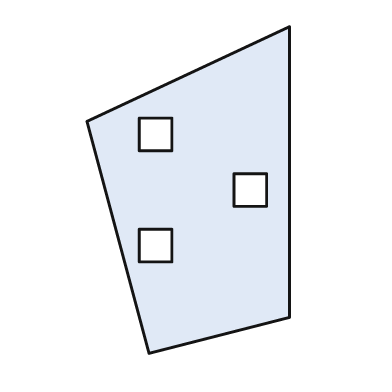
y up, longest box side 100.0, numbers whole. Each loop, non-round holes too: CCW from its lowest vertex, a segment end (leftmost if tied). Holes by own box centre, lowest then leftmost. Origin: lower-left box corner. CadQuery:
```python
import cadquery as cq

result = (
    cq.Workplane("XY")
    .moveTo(19.0, 0.0)
    .lineTo(62.0, 11.0)
    .lineTo(62.0, 100.0)
    .lineTo(0.0, 71.0)
    .close()
    .moveTo(16.0, 28.0)
    .lineTo(26.0, 28.0)
    .lineTo(26.0, 38.0)
    .lineTo(16.0, 38.0)
    .close()
    .moveTo(45.0, 45.0)
    .lineTo(55.0, 45.0)
    .lineTo(55.0, 55.0)
    .lineTo(45.0, 55.0)
    .close()
    .moveTo(16.0, 62.0)
    .lineTo(26.0, 62.0)
    .lineTo(26.0, 72.0)
    .lineTo(16.0, 72.0)
    .close()
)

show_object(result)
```